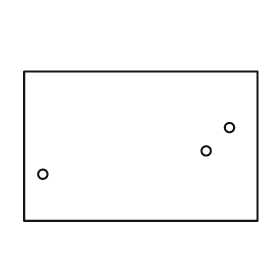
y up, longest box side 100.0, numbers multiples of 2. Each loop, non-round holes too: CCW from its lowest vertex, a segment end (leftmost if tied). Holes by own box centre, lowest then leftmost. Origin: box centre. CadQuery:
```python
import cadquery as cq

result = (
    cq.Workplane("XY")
    .moveTo(-50.0, -32.0)
    .lineTo(50.0, -32.0)
    .lineTo(50.0, 32.0)
    .lineTo(-50.0, 32.0)
    .close()
    .moveTo(-42.0, -12.0)
    .circle(2.0)
    .moveTo(28.0, -2.0)
    .circle(2.0)
    .moveTo(38.0, 8.0)
    .circle(2.0)
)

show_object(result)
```